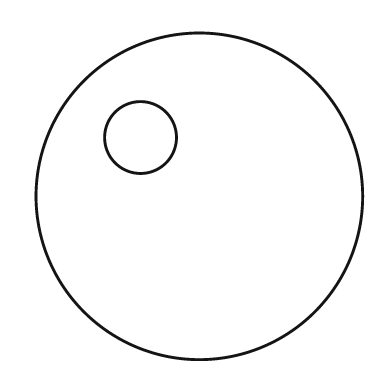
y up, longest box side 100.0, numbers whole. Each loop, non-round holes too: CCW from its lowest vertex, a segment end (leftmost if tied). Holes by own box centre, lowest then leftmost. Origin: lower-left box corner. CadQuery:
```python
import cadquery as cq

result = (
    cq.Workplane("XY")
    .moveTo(50.0, 50.0)
    .circle(50.0)
    .moveTo(32.0, 68.0)
    .circle(11.0)
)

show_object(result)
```